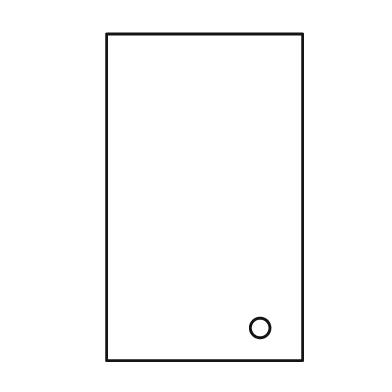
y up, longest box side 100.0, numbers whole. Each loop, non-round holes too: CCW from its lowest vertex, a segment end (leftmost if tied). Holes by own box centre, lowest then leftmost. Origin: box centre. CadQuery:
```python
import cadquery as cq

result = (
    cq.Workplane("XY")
    .moveTo(-30.0, -50.0)
    .lineTo(30.0, -50.0)
    .lineTo(30.0, 50.0)
    .lineTo(-30.0, 50.0)
    .close()
    .moveTo(17.0, -40.0)
    .circle(3.0)
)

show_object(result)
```